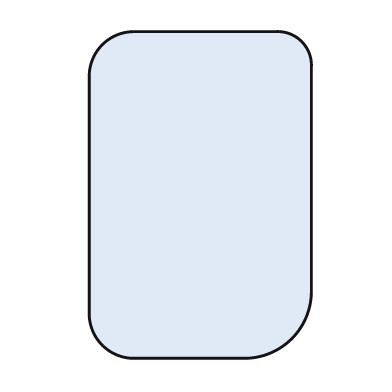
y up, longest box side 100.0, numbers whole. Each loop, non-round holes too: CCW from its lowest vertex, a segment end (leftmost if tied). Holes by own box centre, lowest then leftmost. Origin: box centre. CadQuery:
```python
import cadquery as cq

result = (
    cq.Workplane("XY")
    .moveTo(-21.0, -50.0)
    .lineTo(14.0, -50.0)
    .threePointArc((28.0, -44.0), (34.0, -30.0))
    .lineTo(34.0, 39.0)
    .threePointArc((31.0, 47.0), (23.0, 50.0))
    .lineTo(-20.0, 50.0)
    .threePointArc((-30.0, 46.0), (-34.0, 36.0))
    .lineTo(-34.0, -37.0)
    .threePointArc((-30.0, -46.0), (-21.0, -50.0))
    .close()
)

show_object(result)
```